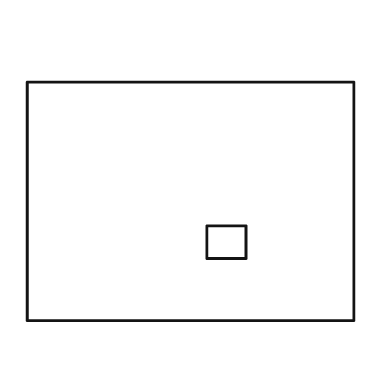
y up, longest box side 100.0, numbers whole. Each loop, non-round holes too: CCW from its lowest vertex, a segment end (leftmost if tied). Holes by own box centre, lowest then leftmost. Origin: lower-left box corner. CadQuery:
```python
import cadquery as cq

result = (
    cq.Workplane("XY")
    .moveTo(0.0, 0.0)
    .lineTo(100.0, 0.0)
    .lineTo(100.0, 73.0)
    .lineTo(0.0, 73.0)
    .close()
    .moveTo(55.0, 19.0)
    .lineTo(67.0, 19.0)
    .lineTo(67.0, 29.0)
    .lineTo(55.0, 29.0)
    .close()
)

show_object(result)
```